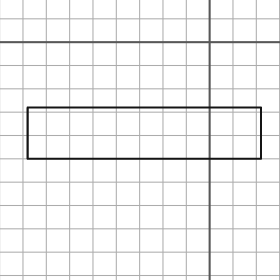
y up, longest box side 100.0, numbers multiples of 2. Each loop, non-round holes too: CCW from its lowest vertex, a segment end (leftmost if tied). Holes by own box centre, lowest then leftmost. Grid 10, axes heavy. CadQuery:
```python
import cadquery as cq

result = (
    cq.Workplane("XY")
    .moveTo(-78.0, -50.0)
    .lineTo(22.0, -50.0)
    .lineTo(22.0, -28.0)
    .lineTo(-78.0, -28.0)
    .close()
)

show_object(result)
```